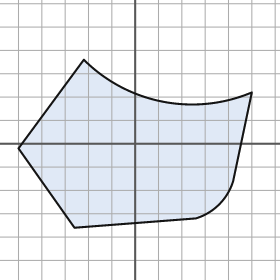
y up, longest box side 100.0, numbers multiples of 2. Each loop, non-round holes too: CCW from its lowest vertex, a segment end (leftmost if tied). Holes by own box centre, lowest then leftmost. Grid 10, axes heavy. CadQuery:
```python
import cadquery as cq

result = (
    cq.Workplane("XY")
    .moveTo(-26.0, -36.0)
    .lineTo(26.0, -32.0)
    .threePointArc((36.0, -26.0), (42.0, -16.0))
    .lineTo(50.0, 22.0)
    .threePointArc((12.0, 18.0), (-22.0, 36.0))
    .lineTo(-50.0, -2.0)
    .close()
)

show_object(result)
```